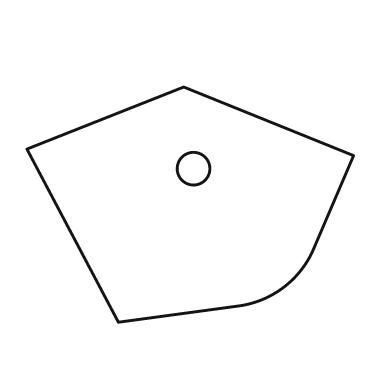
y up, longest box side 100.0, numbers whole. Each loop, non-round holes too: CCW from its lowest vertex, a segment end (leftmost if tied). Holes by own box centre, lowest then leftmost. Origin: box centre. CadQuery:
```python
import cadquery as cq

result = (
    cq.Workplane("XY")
    .moveTo(-22.0, -36.0)
    .lineTo(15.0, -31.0)
    .threePointArc((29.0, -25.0), (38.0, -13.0))
    .lineTo(50.0, 15.0)
    .lineTo(-2.0, 36.0)
    .lineTo(-50.0, 17.0)
    .close()
    .moveTo(1.0, 11.0)
    .circle(5.0)
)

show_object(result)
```